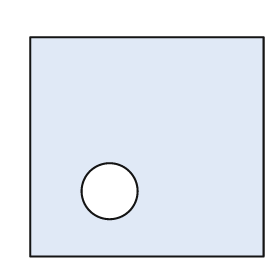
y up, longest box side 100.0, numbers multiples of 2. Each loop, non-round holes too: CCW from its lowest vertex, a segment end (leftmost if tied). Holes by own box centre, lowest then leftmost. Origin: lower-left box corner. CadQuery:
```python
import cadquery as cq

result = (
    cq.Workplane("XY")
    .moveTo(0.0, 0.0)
    .lineTo(100.0, 0.0)
    .lineTo(100.0, 94.0)
    .lineTo(0.0, 94.0)
    .close()
    .moveTo(34.0, 28.0)
    .circle(12.0)
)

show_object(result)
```